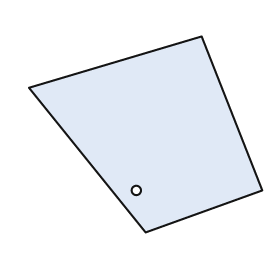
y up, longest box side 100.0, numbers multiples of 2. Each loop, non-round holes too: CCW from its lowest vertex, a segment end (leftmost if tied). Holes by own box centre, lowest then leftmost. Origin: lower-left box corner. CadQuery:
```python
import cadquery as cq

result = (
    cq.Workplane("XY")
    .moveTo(50.0, 0.0)
    .lineTo(100.0, 18.0)
    .lineTo(74.0, 84.0)
    .lineTo(0.0, 62.0)
    .close()
    .moveTo(46.0, 18.0)
    .circle(2.0)
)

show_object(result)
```